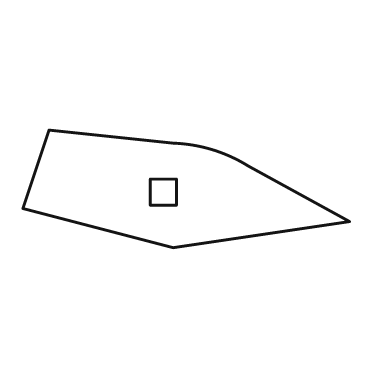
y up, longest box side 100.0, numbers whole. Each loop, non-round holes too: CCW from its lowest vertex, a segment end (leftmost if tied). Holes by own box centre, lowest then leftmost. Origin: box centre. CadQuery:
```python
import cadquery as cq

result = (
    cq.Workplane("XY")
    .moveTo(-4.0, -18.0)
    .lineTo(50.0, -10.0)
    .lineTo(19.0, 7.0)
    .threePointArc((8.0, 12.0), (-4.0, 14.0))
    .lineTo(-42.0, 18.0)
    .lineTo(-50.0, -6.0)
    .close()
    .moveTo(-11.0, -5.0)
    .lineTo(-3.0, -5.0)
    .lineTo(-3.0, 3.0)
    .lineTo(-11.0, 3.0)
    .close()
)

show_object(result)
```